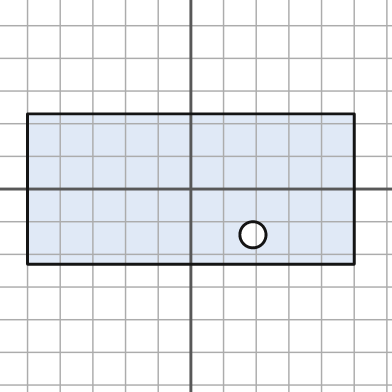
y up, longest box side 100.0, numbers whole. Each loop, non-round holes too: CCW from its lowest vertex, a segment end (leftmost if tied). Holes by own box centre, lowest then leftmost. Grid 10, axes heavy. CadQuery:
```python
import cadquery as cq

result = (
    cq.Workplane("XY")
    .moveTo(-50.0, -23.0)
    .lineTo(50.0, -23.0)
    .lineTo(50.0, 23.0)
    .lineTo(-50.0, 23.0)
    .close()
    .moveTo(19.0, -14.0)
    .circle(4.0)
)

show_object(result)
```